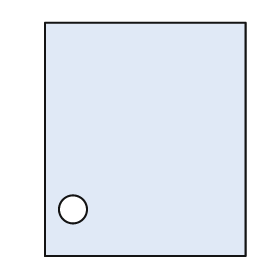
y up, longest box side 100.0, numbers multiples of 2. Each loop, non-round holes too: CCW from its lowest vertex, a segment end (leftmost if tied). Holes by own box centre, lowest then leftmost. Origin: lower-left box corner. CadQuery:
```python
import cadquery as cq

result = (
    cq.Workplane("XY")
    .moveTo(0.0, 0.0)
    .lineTo(86.0, 0.0)
    .lineTo(86.0, 100.0)
    .lineTo(0.0, 100.0)
    .close()
    .moveTo(12.0, 20.0)
    .circle(6.0)
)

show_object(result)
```